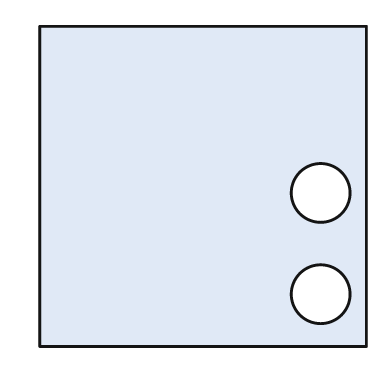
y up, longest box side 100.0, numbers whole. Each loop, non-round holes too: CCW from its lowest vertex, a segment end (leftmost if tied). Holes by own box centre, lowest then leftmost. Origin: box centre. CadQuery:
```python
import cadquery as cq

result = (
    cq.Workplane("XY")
    .moveTo(-50.0, -49.0)
    .lineTo(50.0, -49.0)
    .lineTo(50.0, 49.0)
    .lineTo(-50.0, 49.0)
    .close()
    .moveTo(36.0, -33.0)
    .circle(9.0)
    .moveTo(36.0, -2.0)
    .circle(9.0)
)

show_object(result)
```